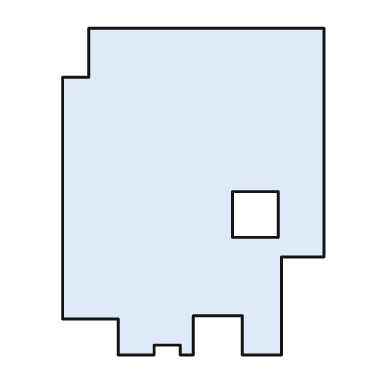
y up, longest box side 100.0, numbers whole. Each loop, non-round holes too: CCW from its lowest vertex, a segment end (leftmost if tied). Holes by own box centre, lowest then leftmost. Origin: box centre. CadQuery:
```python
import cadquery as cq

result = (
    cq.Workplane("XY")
    .moveTo(-23.0, -50.0)
    .lineTo(-12.0, -50.0)
    .lineTo(-12.0, -47.0)
    .lineTo(-4.0, -47.0)
    .lineTo(-4.0, -50.0)
    .lineTo(0.0, -50.0)
    .lineTo(0.0, -38.0)
    .lineTo(15.0, -38.0)
    .lineTo(15.0, -50.0)
    .lineTo(27.0, -50.0)
    .lineTo(27.0, -20.0)
    .lineTo(40.0, -20.0)
    .lineTo(40.0, 50.0)
    .lineTo(-32.0, 50.0)
    .lineTo(-32.0, 35.0)
    .lineTo(-40.0, 35.0)
    .lineTo(-40.0, -39.0)
    .lineTo(-23.0, -39.0)
    .close()
    .moveTo(12.0, -14.0)
    .lineTo(26.0, -14.0)
    .lineTo(26.0, 0.0)
    .lineTo(12.0, 0.0)
    .close()
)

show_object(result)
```